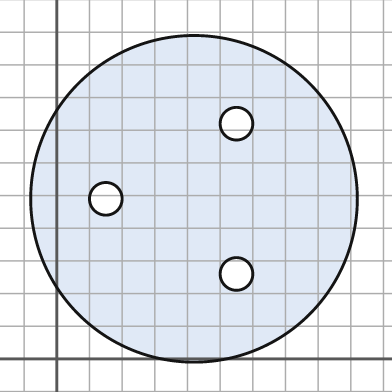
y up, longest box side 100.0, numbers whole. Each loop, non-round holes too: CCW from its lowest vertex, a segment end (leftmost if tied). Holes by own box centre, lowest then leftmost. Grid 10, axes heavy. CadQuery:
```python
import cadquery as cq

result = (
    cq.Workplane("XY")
    .moveTo(42.0, 49.0)
    .circle(50.0)
    .moveTo(55.0, 26.0)
    .circle(5.0)
    .moveTo(15.0, 49.0)
    .circle(5.0)
    .moveTo(55.0, 72.0)
    .circle(5.0)
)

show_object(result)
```